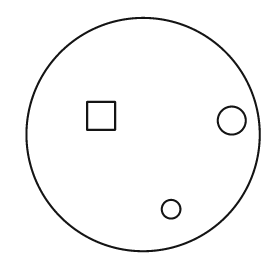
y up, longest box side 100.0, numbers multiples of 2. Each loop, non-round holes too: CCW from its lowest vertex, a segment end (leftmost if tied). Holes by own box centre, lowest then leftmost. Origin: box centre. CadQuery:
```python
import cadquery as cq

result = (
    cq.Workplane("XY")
    .moveTo(0.0, 0.0)
    .circle(50.0)
    .moveTo(12.0, -32.0)
    .circle(4.0)
    .moveTo(38.0, 6.0)
    .circle(6.0)
    .moveTo(-24.0, 2.0)
    .lineTo(-12.0, 2.0)
    .lineTo(-12.0, 14.0)
    .lineTo(-24.0, 14.0)
    .close()
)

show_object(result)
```